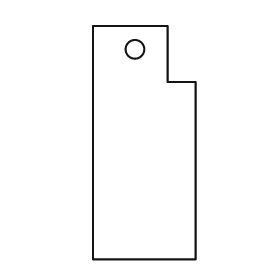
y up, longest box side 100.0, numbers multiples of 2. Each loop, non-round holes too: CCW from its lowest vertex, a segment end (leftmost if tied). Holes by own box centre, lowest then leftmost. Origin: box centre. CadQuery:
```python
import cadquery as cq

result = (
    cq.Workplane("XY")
    .moveTo(-22.0, -50.0)
    .lineTo(22.0, -50.0)
    .lineTo(22.0, 26.0)
    .lineTo(10.0, 26.0)
    .lineTo(10.0, 50.0)
    .lineTo(-22.0, 50.0)
    .close()
    .moveTo(-4.0, 40.0)
    .circle(4.0)
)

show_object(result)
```